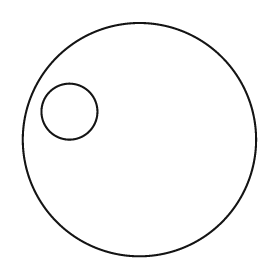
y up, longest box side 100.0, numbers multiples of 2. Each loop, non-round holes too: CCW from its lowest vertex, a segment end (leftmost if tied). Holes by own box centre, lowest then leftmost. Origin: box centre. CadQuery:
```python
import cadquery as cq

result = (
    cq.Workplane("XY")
    .moveTo(0.0, 0.0)
    .circle(50.0)
    .moveTo(-30.0, 12.0)
    .circle(12.0)
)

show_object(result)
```